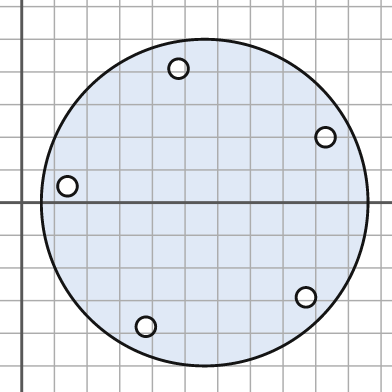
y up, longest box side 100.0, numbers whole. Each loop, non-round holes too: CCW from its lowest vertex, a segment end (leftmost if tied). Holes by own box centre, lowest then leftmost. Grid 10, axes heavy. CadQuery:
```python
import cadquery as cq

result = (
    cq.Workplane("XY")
    .moveTo(56.0, 0.0)
    .circle(50.0)
    .moveTo(38.0, -38.0)
    .circle(3.0)
    .moveTo(87.0, -29.0)
    .circle(3.0)
    .moveTo(14.0, 5.0)
    .circle(3.0)
    .moveTo(93.0, 20.0)
    .circle(3.0)
    .moveTo(48.0, 41.0)
    .circle(3.0)
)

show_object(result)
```